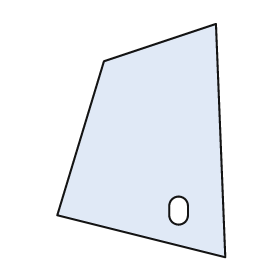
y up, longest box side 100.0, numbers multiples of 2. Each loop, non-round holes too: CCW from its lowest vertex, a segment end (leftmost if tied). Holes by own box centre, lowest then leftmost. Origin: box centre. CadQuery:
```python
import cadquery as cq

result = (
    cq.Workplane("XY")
    .moveTo(36.0, -50.0)
    .lineTo(32.0, 50.0)
    .lineTo(-16.0, 34.0)
    .lineTo(-36.0, -32.0)
    .close()
    .moveTo(12.0, -32.0)
    .threePointArc((16.0, -36.0), (20.0, -32.0))
    .lineTo(20.0, -28.0)
    .threePointArc((16.0, -24.0), (12.0, -28.0))
    .close()
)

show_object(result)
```